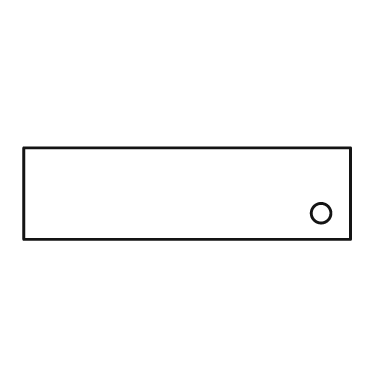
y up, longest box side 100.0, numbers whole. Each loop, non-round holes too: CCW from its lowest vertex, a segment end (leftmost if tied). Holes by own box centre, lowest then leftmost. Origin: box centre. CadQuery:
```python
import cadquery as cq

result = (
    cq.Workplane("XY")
    .moveTo(-50.0, -14.0)
    .lineTo(50.0, -14.0)
    .lineTo(50.0, 14.0)
    .lineTo(-50.0, 14.0)
    .close()
    .moveTo(41.0, -6.0)
    .circle(3.0)
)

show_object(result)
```